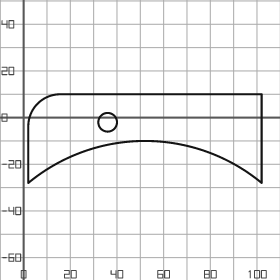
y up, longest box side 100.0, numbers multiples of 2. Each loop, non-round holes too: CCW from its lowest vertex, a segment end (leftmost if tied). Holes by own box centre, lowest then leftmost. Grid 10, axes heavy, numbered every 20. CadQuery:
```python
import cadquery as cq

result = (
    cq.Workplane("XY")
    .moveTo(2.0, -28.0)
    .threePointArc((52.0, -10.0), (102.0, -28.0))
    .lineTo(102.0, 10.0)
    .lineTo(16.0, 10.0)
    .threePointArc((6.0, 6.0), (2.0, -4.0))
    .close()
    .moveTo(36.0, -2.0)
    .circle(4.0)
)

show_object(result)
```